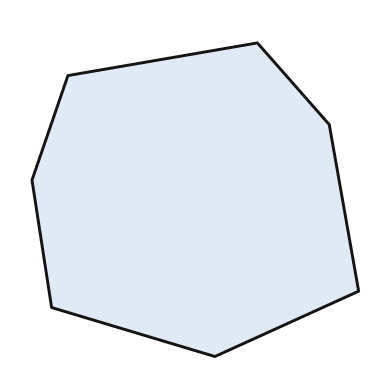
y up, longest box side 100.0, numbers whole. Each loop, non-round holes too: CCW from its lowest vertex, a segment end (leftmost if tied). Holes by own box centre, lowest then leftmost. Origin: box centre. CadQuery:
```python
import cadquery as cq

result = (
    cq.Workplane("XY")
    .moveTo(6.0, -48.0)
    .lineTo(50.0, -28.0)
    .lineTo(41.0, 23.0)
    .lineTo(19.0, 48.0)
    .lineTo(-39.0, 38.0)
    .lineTo(-50.0, 6.0)
    .lineTo(-44.0, -33.0)
    .close()
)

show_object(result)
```